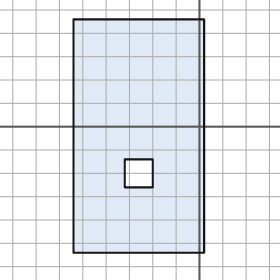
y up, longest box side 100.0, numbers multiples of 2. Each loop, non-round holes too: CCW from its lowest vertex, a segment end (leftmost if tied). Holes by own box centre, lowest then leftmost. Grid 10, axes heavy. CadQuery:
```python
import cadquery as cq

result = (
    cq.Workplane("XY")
    .moveTo(-54.0, -54.0)
    .lineTo(2.0, -54.0)
    .lineTo(2.0, 46.0)
    .lineTo(-54.0, 46.0)
    .close()
    .moveTo(-32.0, -26.0)
    .lineTo(-20.0, -26.0)
    .lineTo(-20.0, -14.0)
    .lineTo(-32.0, -14.0)
    .close()
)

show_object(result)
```